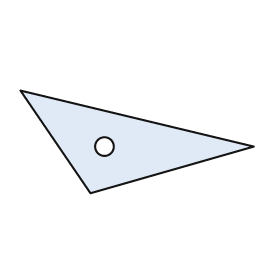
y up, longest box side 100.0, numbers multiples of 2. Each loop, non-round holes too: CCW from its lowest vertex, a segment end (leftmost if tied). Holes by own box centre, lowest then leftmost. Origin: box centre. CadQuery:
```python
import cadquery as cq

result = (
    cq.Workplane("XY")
    .moveTo(-20.0, -22.0)
    .lineTo(50.0, -2.0)
    .lineTo(-50.0, 22.0)
    .close()
    .moveTo(-14.0, -2.0)
    .circle(4.0)
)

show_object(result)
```